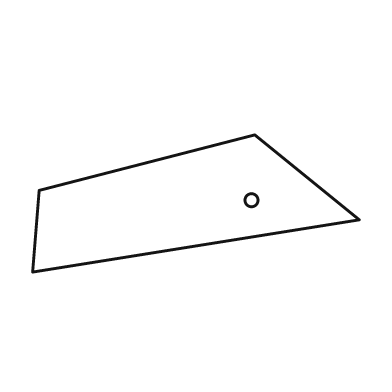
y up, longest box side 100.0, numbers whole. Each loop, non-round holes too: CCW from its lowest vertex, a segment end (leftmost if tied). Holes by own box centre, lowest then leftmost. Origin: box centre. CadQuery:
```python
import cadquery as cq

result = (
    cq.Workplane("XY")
    .moveTo(-50.0, -21.0)
    .lineTo(50.0, -5.0)
    .lineTo(18.0, 21.0)
    .lineTo(-48.0, 4.0)
    .close()
    .moveTo(17.0, 1.0)
    .circle(2.0)
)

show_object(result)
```